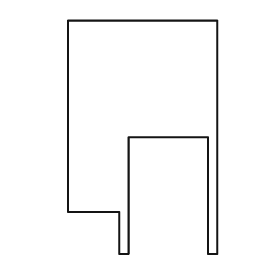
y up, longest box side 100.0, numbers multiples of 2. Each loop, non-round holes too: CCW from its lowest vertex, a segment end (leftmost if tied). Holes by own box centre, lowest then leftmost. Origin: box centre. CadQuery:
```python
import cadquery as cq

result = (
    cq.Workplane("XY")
    .moveTo(-10.0, -50.0)
    .lineTo(-6.0, -50.0)
    .lineTo(-6.0, 0.0)
    .lineTo(28.0, 0.0)
    .lineTo(28.0, -50.0)
    .lineTo(32.0, -50.0)
    .lineTo(32.0, 50.0)
    .lineTo(-32.0, 50.0)
    .lineTo(-32.0, -32.0)
    .lineTo(-10.0, -32.0)
    .close()
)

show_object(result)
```